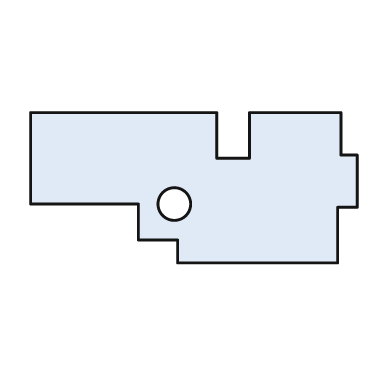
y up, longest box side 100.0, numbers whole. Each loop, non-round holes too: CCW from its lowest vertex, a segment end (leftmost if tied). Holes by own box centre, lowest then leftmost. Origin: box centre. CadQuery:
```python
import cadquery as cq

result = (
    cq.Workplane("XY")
    .moveTo(-5.0, -23.0)
    .lineTo(44.0, -23.0)
    .lineTo(44.0, -6.0)
    .lineTo(50.0, -6.0)
    .lineTo(50.0, 10.0)
    .lineTo(45.0, 10.0)
    .lineTo(45.0, 23.0)
    .lineTo(17.0, 23.0)
    .lineTo(17.0, 9.0)
    .lineTo(7.0, 9.0)
    .lineTo(7.0, 23.0)
    .lineTo(-50.0, 23.0)
    .lineTo(-50.0, -5.0)
    .lineTo(-17.0, -5.0)
    .lineTo(-17.0, -16.0)
    .lineTo(-5.0, -16.0)
    .close()
    .moveTo(-6.0, -5.0)
    .circle(5.0)
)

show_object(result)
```